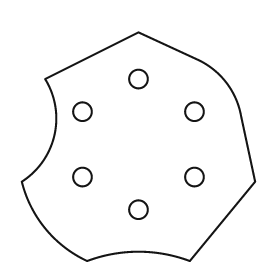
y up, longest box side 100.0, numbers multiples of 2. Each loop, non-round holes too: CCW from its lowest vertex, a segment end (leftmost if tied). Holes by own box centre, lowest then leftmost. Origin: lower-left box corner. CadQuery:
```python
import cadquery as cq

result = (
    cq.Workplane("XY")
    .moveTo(28.0, 0.0)
    .threePointArc((50.0, 4.0), (72.0, 0.0))
    .lineTo(100.0, 34.0)
    .lineTo(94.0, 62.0)
    .threePointArc((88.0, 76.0), (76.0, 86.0))
    .lineTo(50.0, 98.0)
    .lineTo(10.0, 78.0)
    .threePointArc((14.0, 54.0), (0.0, 34.0))
    .threePointArc((10.0, 14.0), (28.0, 0.0))
    .close()
    .moveTo(50.0, 22.0)
    .circle(4.0)
    .moveTo(26.0, 36.0)
    .circle(4.0)
    .moveTo(74.0, 36.0)
    .circle(4.0)
    .moveTo(26.0, 64.0)
    .circle(4.0)
    .moveTo(74.0, 64.0)
    .circle(4.0)
    .moveTo(50.0, 78.0)
    .circle(4.0)
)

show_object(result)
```